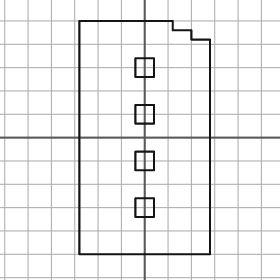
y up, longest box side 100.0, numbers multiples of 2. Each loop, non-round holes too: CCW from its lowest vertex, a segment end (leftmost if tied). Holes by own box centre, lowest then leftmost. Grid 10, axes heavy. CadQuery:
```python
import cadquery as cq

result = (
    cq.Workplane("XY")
    .moveTo(-28.0, -50.0)
    .lineTo(28.0, -50.0)
    .lineTo(28.0, 42.0)
    .lineTo(20.0, 42.0)
    .lineTo(20.0, 46.0)
    .lineTo(12.0, 46.0)
    .lineTo(12.0, 50.0)
    .lineTo(-28.0, 50.0)
    .close()
    .moveTo(-4.0, -34.0)
    .lineTo(4.0, -34.0)
    .lineTo(4.0, -26.0)
    .lineTo(-4.0, -26.0)
    .close()
    .moveTo(-4.0, -14.0)
    .lineTo(4.0, -14.0)
    .lineTo(4.0, -6.0)
    .lineTo(-4.0, -6.0)
    .close()
    .moveTo(-4.0, 6.0)
    .lineTo(4.0, 6.0)
    .lineTo(4.0, 14.0)
    .lineTo(-4.0, 14.0)
    .close()
    .moveTo(-4.0, 26.0)
    .lineTo(4.0, 26.0)
    .lineTo(4.0, 34.0)
    .lineTo(-4.0, 34.0)
    .close()
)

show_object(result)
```